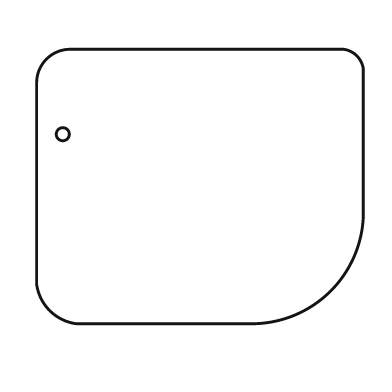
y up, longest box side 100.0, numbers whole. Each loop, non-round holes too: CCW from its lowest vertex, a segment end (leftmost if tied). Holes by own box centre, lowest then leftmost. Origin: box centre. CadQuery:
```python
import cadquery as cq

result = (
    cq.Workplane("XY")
    .moveTo(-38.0, -42.0)
    .lineTo(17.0, -42.0)
    .threePointArc((40.0, -32.0), (50.0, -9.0))
    .lineTo(50.0, 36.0)
    .threePointArc((48.0, 40.0), (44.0, 42.0))
    .lineTo(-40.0, 42.0)
    .threePointArc((-47.0, 39.0), (-50.0, 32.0))
    .lineTo(-50.0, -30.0)
    .threePointArc((-46.0, -38.0), (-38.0, -42.0))
    .close()
    .moveTo(-42.0, 16.0)
    .circle(2.0)
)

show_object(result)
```